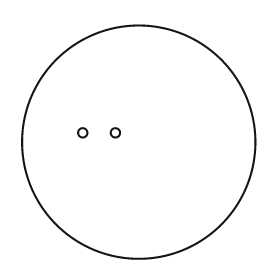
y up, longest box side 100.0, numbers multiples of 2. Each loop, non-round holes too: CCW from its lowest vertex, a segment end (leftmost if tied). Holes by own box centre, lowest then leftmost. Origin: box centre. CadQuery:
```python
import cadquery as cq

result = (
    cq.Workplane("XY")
    .moveTo(0.0, 0.0)
    .circle(50.0)
    .moveTo(-24.0, 4.0)
    .circle(2.0)
    .moveTo(-10.0, 4.0)
    .circle(2.0)
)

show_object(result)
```